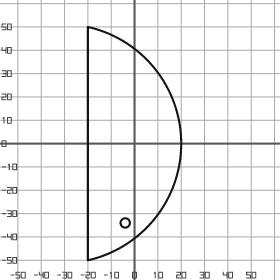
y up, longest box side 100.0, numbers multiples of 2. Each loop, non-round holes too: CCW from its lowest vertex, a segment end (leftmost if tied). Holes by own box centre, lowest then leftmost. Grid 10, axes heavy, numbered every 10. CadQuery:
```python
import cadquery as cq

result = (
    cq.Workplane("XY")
    .moveTo(-20.0, -50.0)
    .threePointArc((20.0, 0.0), (-20.0, 50.0))
    .close()
    .moveTo(-4.0, -34.0)
    .circle(2.0)
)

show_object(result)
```